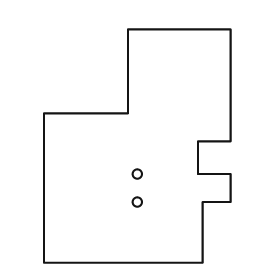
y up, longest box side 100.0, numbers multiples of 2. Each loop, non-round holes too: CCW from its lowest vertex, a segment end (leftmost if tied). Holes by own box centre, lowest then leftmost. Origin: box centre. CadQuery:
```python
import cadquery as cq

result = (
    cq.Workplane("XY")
    .moveTo(-40.0, -50.0)
    .lineTo(28.0, -50.0)
    .lineTo(28.0, -24.0)
    .lineTo(40.0, -24.0)
    .lineTo(40.0, -12.0)
    .lineTo(26.0, -12.0)
    .lineTo(26.0, 2.0)
    .lineTo(40.0, 2.0)
    .lineTo(40.0, 50.0)
    .lineTo(-4.0, 50.0)
    .lineTo(-4.0, 14.0)
    .lineTo(-40.0, 14.0)
    .close()
    .moveTo(0.0, -24.0)
    .circle(2.0)
    .moveTo(0.0, -12.0)
    .circle(2.0)
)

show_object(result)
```